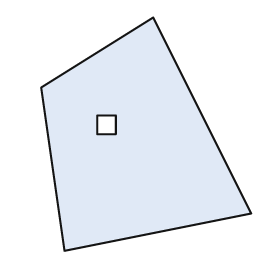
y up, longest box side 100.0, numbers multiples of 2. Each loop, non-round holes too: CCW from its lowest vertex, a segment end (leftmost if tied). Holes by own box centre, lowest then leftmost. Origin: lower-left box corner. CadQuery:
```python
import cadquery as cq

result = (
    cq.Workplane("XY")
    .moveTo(10.0, 0.0)
    .lineTo(90.0, 16.0)
    .lineTo(48.0, 100.0)
    .lineTo(0.0, 70.0)
    .close()
    .moveTo(24.0, 50.0)
    .lineTo(32.0, 50.0)
    .lineTo(32.0, 58.0)
    .lineTo(24.0, 58.0)
    .close()
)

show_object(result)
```